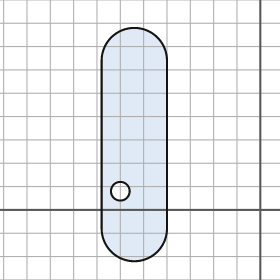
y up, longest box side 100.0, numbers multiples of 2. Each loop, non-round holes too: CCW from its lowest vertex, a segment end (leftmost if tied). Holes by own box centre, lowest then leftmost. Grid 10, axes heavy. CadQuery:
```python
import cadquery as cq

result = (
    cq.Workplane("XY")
    .moveTo(-68.0, -8.0)
    .threePointArc((-54.0, -22.0), (-40.0, -8.0))
    .lineTo(-40.0, 64.0)
    .threePointArc((-54.0, 78.0), (-68.0, 64.0))
    .close()
    .moveTo(-60.0, 8.0)
    .circle(4.0)
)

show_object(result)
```